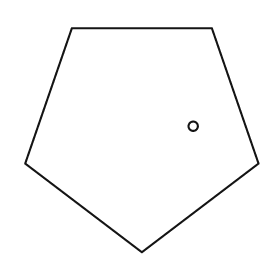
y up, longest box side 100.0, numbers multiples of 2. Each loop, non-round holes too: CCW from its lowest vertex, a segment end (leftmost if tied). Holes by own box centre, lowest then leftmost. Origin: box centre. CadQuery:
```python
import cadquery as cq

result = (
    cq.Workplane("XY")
    .moveTo(0.0, -48.0)
    .lineTo(50.0, -10.0)
    .lineTo(30.0, 48.0)
    .lineTo(-30.0, 48.0)
    .lineTo(-50.0, -10.0)
    .close()
    .moveTo(22.0, 6.0)
    .circle(2.0)
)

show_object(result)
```